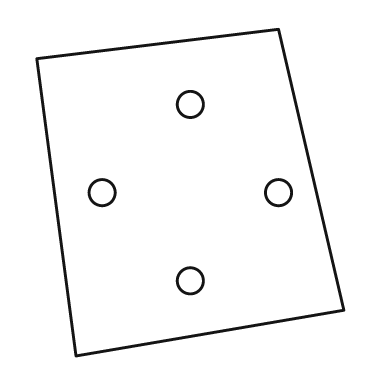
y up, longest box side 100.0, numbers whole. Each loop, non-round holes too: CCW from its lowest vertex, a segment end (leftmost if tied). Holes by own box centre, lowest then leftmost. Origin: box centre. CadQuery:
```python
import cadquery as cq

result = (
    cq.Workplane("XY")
    .moveTo(-35.0, -50.0)
    .lineTo(47.0, -36.0)
    .lineTo(27.0, 50.0)
    .lineTo(-47.0, 41.0)
    .close()
    .moveTo(0.0, -27.0)
    .circle(4.0)
    .moveTo(-27.0, 0.0)
    .circle(4.0)
    .moveTo(27.0, 0.0)
    .circle(4.0)
    .moveTo(0.0, 27.0)
    .circle(4.0)
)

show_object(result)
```